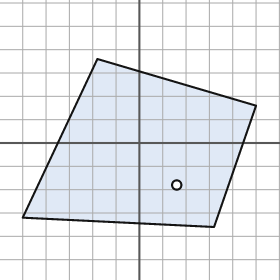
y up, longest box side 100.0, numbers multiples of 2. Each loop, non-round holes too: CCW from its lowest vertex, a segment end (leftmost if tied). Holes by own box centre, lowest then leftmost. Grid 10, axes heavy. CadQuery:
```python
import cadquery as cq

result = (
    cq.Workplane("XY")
    .moveTo(32.0, -36.0)
    .lineTo(50.0, 16.0)
    .lineTo(-18.0, 36.0)
    .lineTo(-50.0, -32.0)
    .close()
    .moveTo(16.0, -18.0)
    .circle(2.0)
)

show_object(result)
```